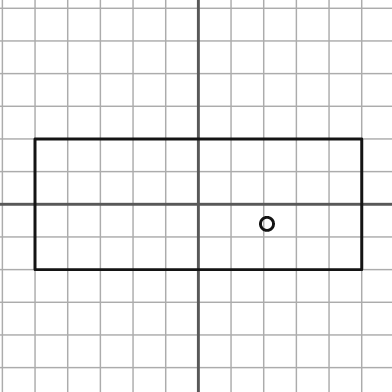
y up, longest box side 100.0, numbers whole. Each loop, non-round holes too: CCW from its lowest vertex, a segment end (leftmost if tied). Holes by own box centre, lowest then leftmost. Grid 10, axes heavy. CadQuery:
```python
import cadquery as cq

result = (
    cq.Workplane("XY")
    .moveTo(-50.0, -20.0)
    .lineTo(50.0, -20.0)
    .lineTo(50.0, 20.0)
    .lineTo(-50.0, 20.0)
    .close()
    .moveTo(21.0, -6.0)
    .circle(2.0)
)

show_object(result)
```